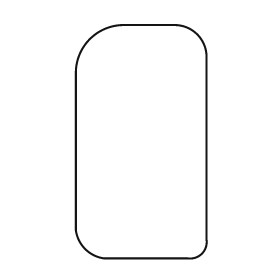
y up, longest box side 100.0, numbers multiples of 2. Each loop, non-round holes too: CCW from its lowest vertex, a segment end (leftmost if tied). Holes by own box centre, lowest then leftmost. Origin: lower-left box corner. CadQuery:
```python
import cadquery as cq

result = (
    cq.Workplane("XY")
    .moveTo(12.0, 0.0)
    .lineTo(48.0, 0.0)
    .threePointArc((54.0, 2.0), (56.0, 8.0))
    .lineTo(56.0, 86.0)
    .threePointArc((52.0, 96.0), (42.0, 100.0))
    .lineTo(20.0, 100.0)
    .threePointArc((6.0, 94.0), (0.0, 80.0))
    .lineTo(0.0, 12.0)
    .threePointArc((4.0, 4.0), (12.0, 0.0))
    .close()
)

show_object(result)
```